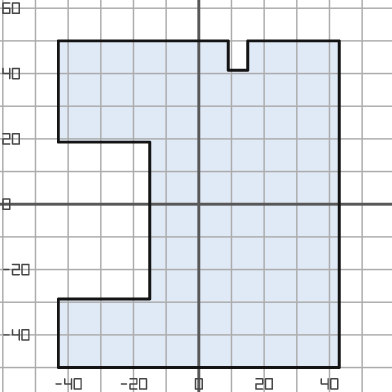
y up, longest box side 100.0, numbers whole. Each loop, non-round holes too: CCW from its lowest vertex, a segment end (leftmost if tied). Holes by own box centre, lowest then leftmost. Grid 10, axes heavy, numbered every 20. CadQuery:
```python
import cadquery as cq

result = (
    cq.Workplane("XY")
    .moveTo(-43.0, -50.0)
    .lineTo(43.0, -50.0)
    .lineTo(43.0, 50.0)
    .lineTo(15.0, 50.0)
    .lineTo(15.0, 41.0)
    .lineTo(9.0, 41.0)
    .lineTo(9.0, 50.0)
    .lineTo(-43.0, 50.0)
    .lineTo(-43.0, 19.0)
    .lineTo(-15.0, 19.0)
    .lineTo(-15.0, -29.0)
    .lineTo(-43.0, -29.0)
    .close()
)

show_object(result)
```